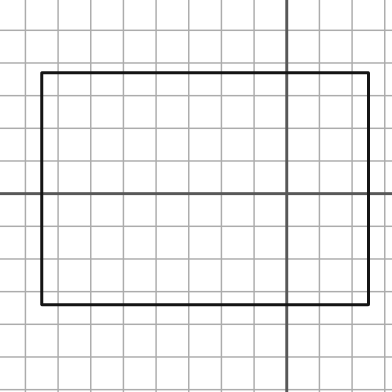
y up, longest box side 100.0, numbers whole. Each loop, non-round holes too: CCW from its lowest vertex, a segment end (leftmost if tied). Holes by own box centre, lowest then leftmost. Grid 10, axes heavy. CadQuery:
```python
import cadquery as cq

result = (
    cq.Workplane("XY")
    .moveTo(-75.0, -34.0)
    .lineTo(25.0, -34.0)
    .lineTo(25.0, 37.0)
    .lineTo(-75.0, 37.0)
    .close()
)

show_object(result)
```